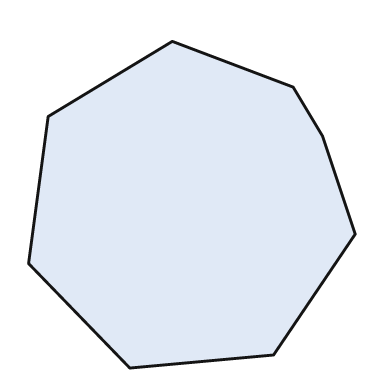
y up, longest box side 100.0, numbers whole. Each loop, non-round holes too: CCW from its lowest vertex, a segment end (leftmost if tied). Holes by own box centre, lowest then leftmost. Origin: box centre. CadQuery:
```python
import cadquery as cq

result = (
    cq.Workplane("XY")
    .moveTo(-19.0, -50.0)
    .lineTo(25.0, -46.0)
    .lineTo(50.0, -9.0)
    .lineTo(40.0, 21.0)
    .lineTo(31.0, 36.0)
    .lineTo(-6.0, 50.0)
    .lineTo(-44.0, 27.0)
    .lineTo(-50.0, -18.0)
    .close()
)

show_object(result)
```